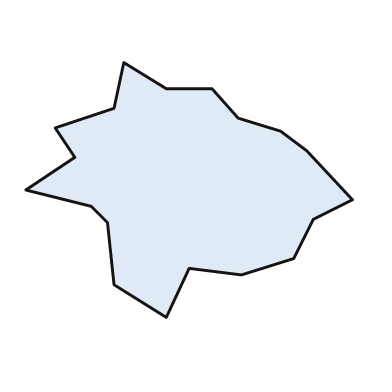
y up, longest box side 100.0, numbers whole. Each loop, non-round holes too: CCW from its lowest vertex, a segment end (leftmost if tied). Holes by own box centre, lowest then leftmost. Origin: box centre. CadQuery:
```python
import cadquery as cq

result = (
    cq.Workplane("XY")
    .moveTo(-7.0, -39.0)
    .lineTo(0.0, -24.0)
    .lineTo(16.0, -26.0)
    .lineTo(32.0, -21.0)
    .lineTo(38.0, -9.0)
    .lineTo(50.0, -3.0)
    .lineTo(36.0, 12.0)
    .lineTo(28.0, 18.0)
    .lineTo(15.0, 22.0)
    .lineTo(7.0, 31.0)
    .lineTo(-7.0, 31.0)
    .lineTo(-20.0, 39.0)
    .lineTo(-23.0, 25.0)
    .lineTo(-41.0, 19.0)
    .lineTo(-35.0, 10.0)
    .lineTo(-50.0, 0.0)
    .lineTo(-30.0, -5.0)
    .lineTo(-25.0, -10.0)
    .lineTo(-23.0, -29.0)
    .close()
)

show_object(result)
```